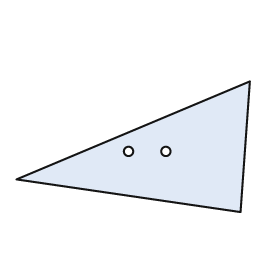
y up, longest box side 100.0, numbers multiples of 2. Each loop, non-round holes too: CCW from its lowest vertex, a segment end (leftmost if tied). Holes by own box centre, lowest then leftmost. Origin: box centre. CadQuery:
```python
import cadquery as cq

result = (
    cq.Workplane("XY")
    .moveTo(46.0, -28.0)
    .lineTo(50.0, 28.0)
    .lineTo(-50.0, -14.0)
    .close()
    .moveTo(-2.0, -2.0)
    .circle(2.0)
    .moveTo(14.0, -2.0)
    .circle(2.0)
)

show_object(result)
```